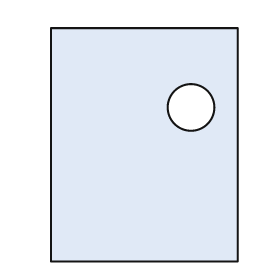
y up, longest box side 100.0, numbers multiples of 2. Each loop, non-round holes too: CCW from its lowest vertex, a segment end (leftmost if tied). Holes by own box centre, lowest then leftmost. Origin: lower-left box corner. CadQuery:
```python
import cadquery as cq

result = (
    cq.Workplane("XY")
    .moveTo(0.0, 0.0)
    .lineTo(80.0, 0.0)
    .lineTo(80.0, 100.0)
    .lineTo(0.0, 100.0)
    .close()
    .moveTo(60.0, 66.0)
    .circle(10.0)
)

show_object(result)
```